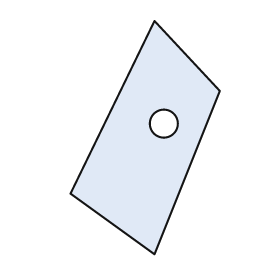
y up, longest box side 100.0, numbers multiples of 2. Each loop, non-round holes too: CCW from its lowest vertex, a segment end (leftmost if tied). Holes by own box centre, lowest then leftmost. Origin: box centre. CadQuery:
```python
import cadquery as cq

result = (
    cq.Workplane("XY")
    .moveTo(4.0, -50.0)
    .lineTo(32.0, 20.0)
    .lineTo(4.0, 50.0)
    .lineTo(-32.0, -24.0)
    .close()
    .moveTo(8.0, 6.0)
    .circle(6.0)
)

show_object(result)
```